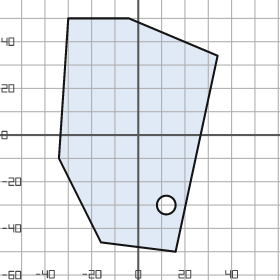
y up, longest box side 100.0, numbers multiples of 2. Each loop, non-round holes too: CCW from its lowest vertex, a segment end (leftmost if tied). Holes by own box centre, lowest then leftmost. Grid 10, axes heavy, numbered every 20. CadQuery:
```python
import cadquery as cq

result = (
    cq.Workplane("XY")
    .moveTo(16.0, -50.0)
    .lineTo(34.0, 34.0)
    .lineTo(-4.0, 50.0)
    .lineTo(-30.0, 50.0)
    .lineTo(-34.0, -10.0)
    .lineTo(-16.0, -46.0)
    .close()
    .moveTo(12.0, -30.0)
    .circle(4.0)
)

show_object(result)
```